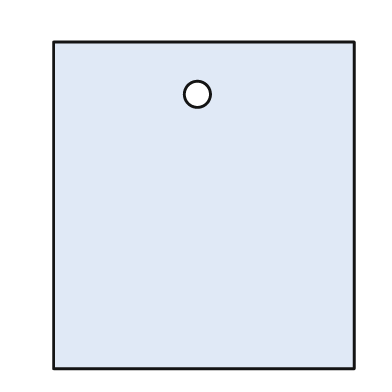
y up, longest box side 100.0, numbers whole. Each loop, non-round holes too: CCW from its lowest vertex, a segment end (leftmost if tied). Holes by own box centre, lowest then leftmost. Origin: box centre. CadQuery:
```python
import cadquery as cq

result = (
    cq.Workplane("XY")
    .moveTo(-46.0, -50.0)
    .lineTo(46.0, -50.0)
    .lineTo(46.0, 50.0)
    .lineTo(-46.0, 50.0)
    .close()
    .moveTo(-2.0, 34.0)
    .circle(4.0)
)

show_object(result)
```